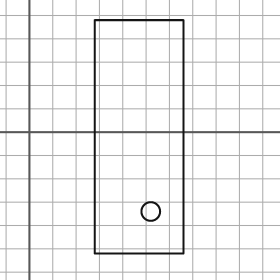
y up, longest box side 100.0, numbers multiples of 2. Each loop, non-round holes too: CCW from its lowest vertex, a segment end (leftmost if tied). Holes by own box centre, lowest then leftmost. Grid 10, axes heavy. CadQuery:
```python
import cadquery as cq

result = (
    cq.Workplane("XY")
    .moveTo(28.0, -52.0)
    .lineTo(66.0, -52.0)
    .lineTo(66.0, 48.0)
    .lineTo(28.0, 48.0)
    .close()
    .moveTo(52.0, -34.0)
    .circle(4.0)
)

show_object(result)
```